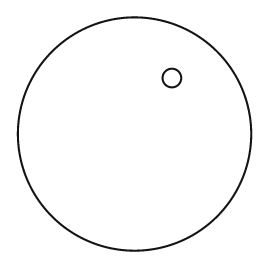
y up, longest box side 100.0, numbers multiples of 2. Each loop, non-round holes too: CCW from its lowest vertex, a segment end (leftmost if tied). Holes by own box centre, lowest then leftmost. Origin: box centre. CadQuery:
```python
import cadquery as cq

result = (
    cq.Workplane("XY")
    .moveTo(0.0, 0.0)
    .circle(50.0)
    .moveTo(16.0, 24.0)
    .circle(4.0)
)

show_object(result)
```